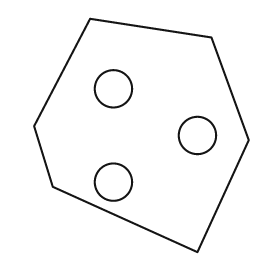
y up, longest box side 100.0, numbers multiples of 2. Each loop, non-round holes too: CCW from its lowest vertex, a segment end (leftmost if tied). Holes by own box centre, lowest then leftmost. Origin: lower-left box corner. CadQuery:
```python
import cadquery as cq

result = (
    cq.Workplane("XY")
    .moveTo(70.0, 0.0)
    .lineTo(92.0, 48.0)
    .lineTo(76.0, 92.0)
    .lineTo(24.0, 100.0)
    .lineTo(0.0, 54.0)
    .lineTo(8.0, 28.0)
    .close()
    .moveTo(34.0, 30.0)
    .circle(8.0)
    .moveTo(70.0, 50.0)
    .circle(8.0)
    .moveTo(34.0, 70.0)
    .circle(8.0)
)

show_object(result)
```